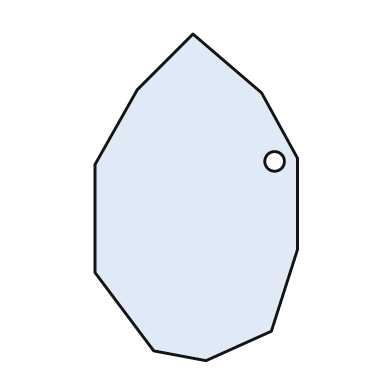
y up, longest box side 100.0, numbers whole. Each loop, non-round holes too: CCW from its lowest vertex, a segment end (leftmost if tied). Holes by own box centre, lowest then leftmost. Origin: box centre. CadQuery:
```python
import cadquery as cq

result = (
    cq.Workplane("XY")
    .moveTo(3.0, -50.0)
    .lineTo(23.0, -41.0)
    .lineTo(31.0, -16.0)
    .lineTo(31.0, 12.0)
    .lineTo(20.0, 32.0)
    .lineTo(-1.0, 50.0)
    .lineTo(-18.0, 33.0)
    .lineTo(-31.0, 10.0)
    .lineTo(-31.0, -23.0)
    .lineTo(-13.0, -47.0)
    .close()
    .moveTo(24.0, 11.0)
    .circle(3.0)
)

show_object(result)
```